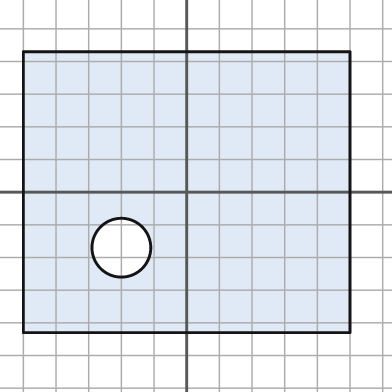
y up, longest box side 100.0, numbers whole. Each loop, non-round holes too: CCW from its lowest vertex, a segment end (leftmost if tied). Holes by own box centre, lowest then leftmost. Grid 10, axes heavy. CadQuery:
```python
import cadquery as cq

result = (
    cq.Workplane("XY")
    .moveTo(-50.0, -43.0)
    .lineTo(50.0, -43.0)
    .lineTo(50.0, 43.0)
    .lineTo(-50.0, 43.0)
    .close()
    .moveTo(-20.0, -17.0)
    .circle(9.0)
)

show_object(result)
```